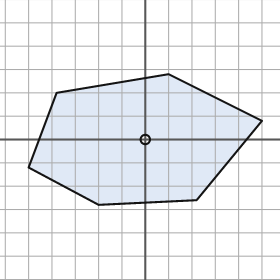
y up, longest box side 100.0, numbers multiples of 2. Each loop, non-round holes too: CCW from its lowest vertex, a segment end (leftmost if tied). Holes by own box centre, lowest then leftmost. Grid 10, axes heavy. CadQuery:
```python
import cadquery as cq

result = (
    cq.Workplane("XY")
    .moveTo(-20.0, -28.0)
    .lineTo(22.0, -26.0)
    .lineTo(50.0, 8.0)
    .lineTo(10.0, 28.0)
    .lineTo(-38.0, 20.0)
    .lineTo(-50.0, -12.0)
    .close()
    .moveTo(0.0, 0.0)
    .circle(2.0)
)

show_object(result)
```